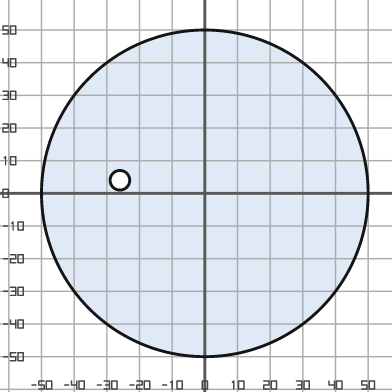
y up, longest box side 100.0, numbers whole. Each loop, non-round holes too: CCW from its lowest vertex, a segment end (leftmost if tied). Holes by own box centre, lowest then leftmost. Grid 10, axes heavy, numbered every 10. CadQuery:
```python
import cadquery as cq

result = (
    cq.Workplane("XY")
    .moveTo(0.0, 0.0)
    .circle(50.0)
    .moveTo(-26.0, 4.0)
    .circle(3.0)
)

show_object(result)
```